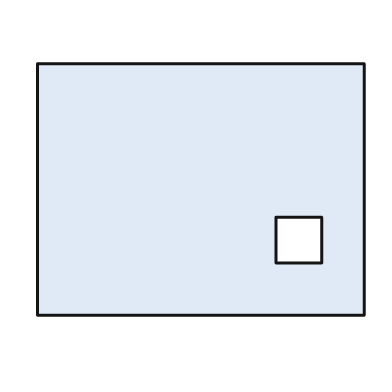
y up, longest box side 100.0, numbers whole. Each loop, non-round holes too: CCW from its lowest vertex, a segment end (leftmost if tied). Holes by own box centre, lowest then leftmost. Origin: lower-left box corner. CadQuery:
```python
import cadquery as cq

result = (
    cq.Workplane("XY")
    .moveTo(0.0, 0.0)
    .lineTo(100.0, 0.0)
    .lineTo(100.0, 77.0)
    .lineTo(0.0, 77.0)
    .close()
    .moveTo(73.0, 16.0)
    .lineTo(87.0, 16.0)
    .lineTo(87.0, 30.0)
    .lineTo(73.0, 30.0)
    .close()
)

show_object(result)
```